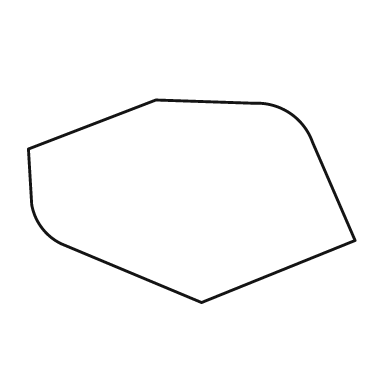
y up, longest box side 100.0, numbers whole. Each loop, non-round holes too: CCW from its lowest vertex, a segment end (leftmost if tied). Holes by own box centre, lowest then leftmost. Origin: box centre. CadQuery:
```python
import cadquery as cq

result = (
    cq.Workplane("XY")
    .moveTo(3.0, -31.0)
    .lineTo(50.0, -12.0)
    .lineTo(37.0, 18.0)
    .threePointArc((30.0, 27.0), (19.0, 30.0))
    .lineTo(-11.0, 31.0)
    .lineTo(-50.0, 16.0)
    .lineTo(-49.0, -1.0)
    .threePointArc((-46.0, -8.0), (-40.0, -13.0))
    .close()
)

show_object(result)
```